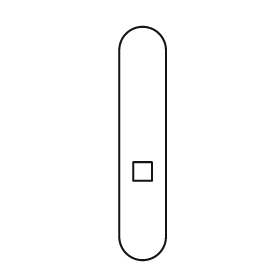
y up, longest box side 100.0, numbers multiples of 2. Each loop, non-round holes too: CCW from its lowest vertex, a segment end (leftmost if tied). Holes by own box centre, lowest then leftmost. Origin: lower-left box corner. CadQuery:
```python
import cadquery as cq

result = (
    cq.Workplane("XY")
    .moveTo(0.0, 10.0)
    .threePointArc((10.0, 0.0), (20.0, 10.0))
    .lineTo(20.0, 90.0)
    .threePointArc((10.0, 100.0), (0.0, 90.0))
    .close()
    .moveTo(6.0, 34.0)
    .lineTo(14.0, 34.0)
    .lineTo(14.0, 42.0)
    .lineTo(6.0, 42.0)
    .close()
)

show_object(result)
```